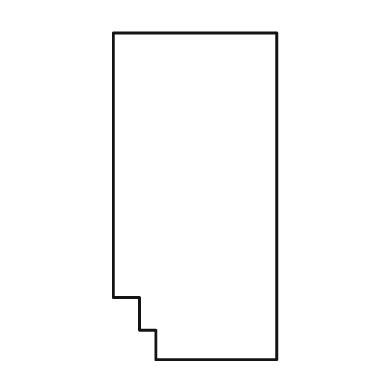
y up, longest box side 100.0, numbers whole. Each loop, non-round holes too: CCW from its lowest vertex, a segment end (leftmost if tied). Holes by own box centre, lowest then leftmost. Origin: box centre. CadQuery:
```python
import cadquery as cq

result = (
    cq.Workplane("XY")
    .moveTo(-12.0, -50.0)
    .lineTo(25.0, -50.0)
    .lineTo(25.0, 50.0)
    .lineTo(-25.0, 50.0)
    .lineTo(-25.0, -31.0)
    .lineTo(-17.0, -31.0)
    .lineTo(-17.0, -41.0)
    .lineTo(-12.0, -41.0)
    .close()
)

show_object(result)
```